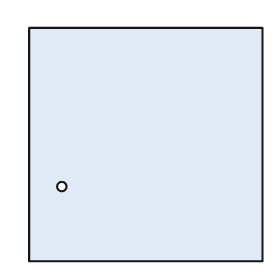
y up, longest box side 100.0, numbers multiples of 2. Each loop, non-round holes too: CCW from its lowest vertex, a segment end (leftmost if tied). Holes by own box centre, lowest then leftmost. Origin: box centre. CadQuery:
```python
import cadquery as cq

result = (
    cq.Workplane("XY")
    .moveTo(-50.0, -50.0)
    .lineTo(50.0, -50.0)
    .lineTo(50.0, 50.0)
    .lineTo(-50.0, 50.0)
    .close()
    .moveTo(-36.0, -18.0)
    .circle(2.0)
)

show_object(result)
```